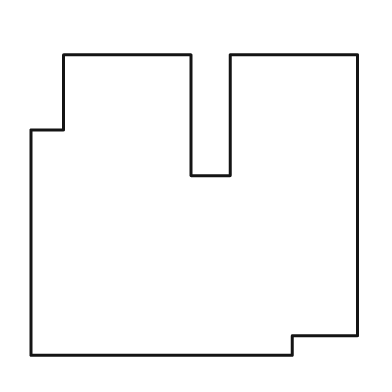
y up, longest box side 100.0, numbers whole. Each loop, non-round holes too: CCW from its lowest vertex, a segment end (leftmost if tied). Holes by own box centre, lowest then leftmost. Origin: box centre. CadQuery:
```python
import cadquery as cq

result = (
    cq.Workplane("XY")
    .moveTo(-50.0, -46.0)
    .lineTo(30.0, -46.0)
    .lineTo(30.0, -40.0)
    .lineTo(50.0, -40.0)
    .lineTo(50.0, 46.0)
    .lineTo(11.0, 46.0)
    .lineTo(11.0, 9.0)
    .lineTo(-1.0, 9.0)
    .lineTo(-1.0, 46.0)
    .lineTo(-40.0, 46.0)
    .lineTo(-40.0, 23.0)
    .lineTo(-50.0, 23.0)
    .close()
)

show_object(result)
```